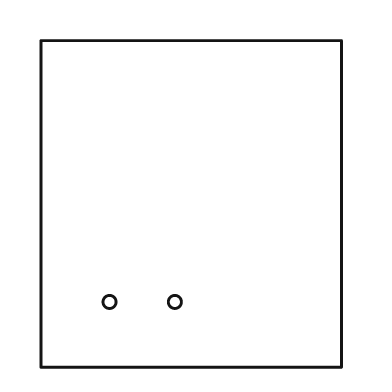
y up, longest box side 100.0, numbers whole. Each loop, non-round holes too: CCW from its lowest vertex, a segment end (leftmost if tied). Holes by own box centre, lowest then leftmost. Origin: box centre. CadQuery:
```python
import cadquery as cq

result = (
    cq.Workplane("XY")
    .moveTo(-46.0, -50.0)
    .lineTo(46.0, -50.0)
    .lineTo(46.0, 50.0)
    .lineTo(-46.0, 50.0)
    .close()
    .moveTo(-25.0, -30.0)
    .circle(2.0)
    .moveTo(-5.0, -30.0)
    .circle(2.0)
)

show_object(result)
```